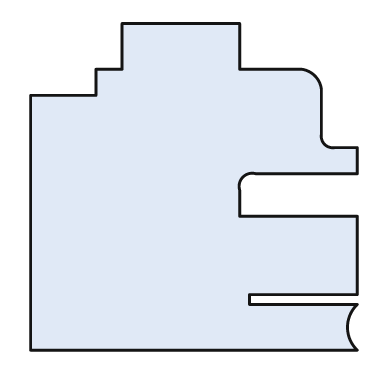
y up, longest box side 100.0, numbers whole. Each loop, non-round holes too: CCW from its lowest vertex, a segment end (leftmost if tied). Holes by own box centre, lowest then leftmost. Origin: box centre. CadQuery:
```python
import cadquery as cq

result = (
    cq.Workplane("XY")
    .moveTo(-50.0, -50.0)
    .lineTo(50.0, -50.0)
    .threePointArc((47.0, -43.0), (50.0, -36.0))
    .lineTo(17.0, -36.0)
    .lineTo(17.0, -33.0)
    .lineTo(50.0, -33.0)
    .lineTo(50.0, -9.0)
    .lineTo(14.0, -9.0)
    .lineTo(14.0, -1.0)
    .threePointArc((15.0, 3.0), (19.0, 4.0))
    .lineTo(50.0, 4.0)
    .lineTo(50.0, 12.0)
    .lineTo(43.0, 12.0)
    .threePointArc((40.0, 13.0), (39.0, 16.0))
    .lineTo(39.0, 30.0)
    .threePointArc((37.0, 34.0), (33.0, 36.0))
    .lineTo(14.0, 36.0)
    .lineTo(14.0, 50.0)
    .lineTo(-22.0, 50.0)
    .lineTo(-22.0, 36.0)
    .lineTo(-30.0, 36.0)
    .lineTo(-30.0, 28.0)
    .lineTo(-50.0, 28.0)
    .close()
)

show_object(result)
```